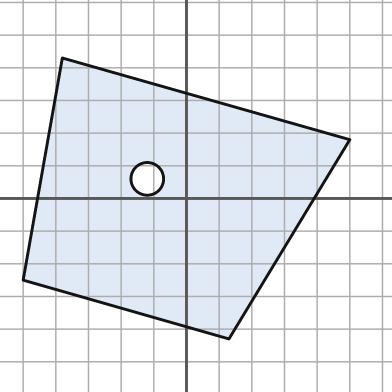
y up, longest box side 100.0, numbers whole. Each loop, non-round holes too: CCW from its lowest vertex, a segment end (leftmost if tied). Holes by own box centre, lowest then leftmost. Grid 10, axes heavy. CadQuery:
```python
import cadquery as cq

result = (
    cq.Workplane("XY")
    .moveTo(13.0, -43.0)
    .lineTo(50.0, 18.0)
    .lineTo(-38.0, 43.0)
    .lineTo(-50.0, -25.0)
    .close()
    .moveTo(-12.0, 6.0)
    .circle(5.0)
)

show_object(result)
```